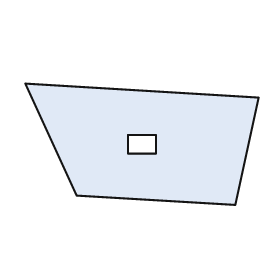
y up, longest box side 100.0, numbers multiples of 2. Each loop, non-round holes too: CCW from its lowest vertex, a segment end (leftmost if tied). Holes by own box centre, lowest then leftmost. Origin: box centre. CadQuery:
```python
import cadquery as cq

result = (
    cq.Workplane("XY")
    .moveTo(40.0, -26.0)
    .lineTo(50.0, 20.0)
    .lineTo(-50.0, 26.0)
    .lineTo(-28.0, -22.0)
    .close()
    .moveTo(-6.0, -4.0)
    .lineTo(6.0, -4.0)
    .lineTo(6.0, 4.0)
    .lineTo(-6.0, 4.0)
    .close()
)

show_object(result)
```